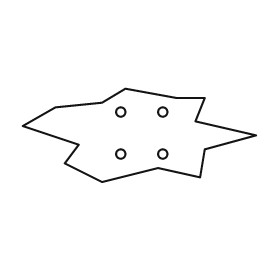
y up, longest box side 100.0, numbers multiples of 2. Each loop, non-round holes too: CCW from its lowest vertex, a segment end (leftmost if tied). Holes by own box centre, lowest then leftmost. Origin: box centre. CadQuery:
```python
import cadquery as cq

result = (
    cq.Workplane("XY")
    .moveTo(-16.0, -20.0)
    .lineTo(8.0, -14.0)
    .lineTo(26.0, -18.0)
    .lineTo(28.0, -6.0)
    .lineTo(50.0, 0.0)
    .lineTo(24.0, 6.0)
    .lineTo(28.0, 16.0)
    .lineTo(16.0, 16.0)
    .lineTo(-6.0, 20.0)
    .lineTo(-16.0, 14.0)
    .lineTo(-36.0, 12.0)
    .lineTo(-50.0, 4.0)
    .lineTo(-26.0, -4.0)
    .lineTo(-32.0, -12.0)
    .close()
    .moveTo(-8.0, -8.0)
    .circle(2.0)
    .moveTo(10.0, -8.0)
    .circle(2.0)
    .moveTo(-8.0, 10.0)
    .circle(2.0)
    .moveTo(10.0, 10.0)
    .circle(2.0)
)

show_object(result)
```